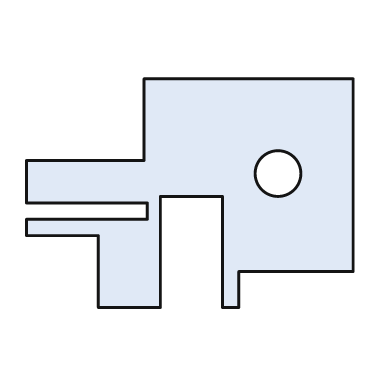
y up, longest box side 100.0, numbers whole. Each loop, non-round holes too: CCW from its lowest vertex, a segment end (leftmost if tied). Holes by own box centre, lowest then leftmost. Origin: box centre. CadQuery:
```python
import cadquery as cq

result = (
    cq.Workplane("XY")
    .moveTo(-28.0, -35.0)
    .lineTo(-9.0, -35.0)
    .lineTo(-9.0, -1.0)
    .lineTo(10.0, -1.0)
    .lineTo(10.0, -35.0)
    .lineTo(15.0, -35.0)
    .lineTo(15.0, -24.0)
    .lineTo(50.0, -24.0)
    .lineTo(50.0, 35.0)
    .lineTo(-14.0, 35.0)
    .lineTo(-14.0, 10.0)
    .lineTo(-50.0, 10.0)
    .lineTo(-50.0, -3.0)
    .lineTo(-13.0, -3.0)
    .lineTo(-13.0, -8.0)
    .lineTo(-50.0, -8.0)
    .lineTo(-50.0, -13.0)
    .lineTo(-28.0, -13.0)
    .close()
    .moveTo(27.0, 6.0)
    .circle(7.0)
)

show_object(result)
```